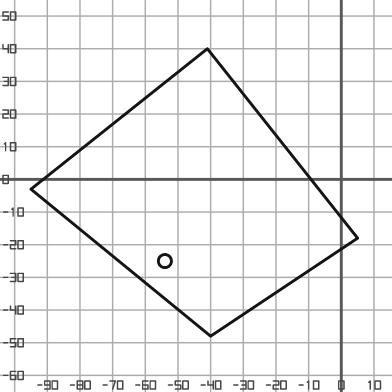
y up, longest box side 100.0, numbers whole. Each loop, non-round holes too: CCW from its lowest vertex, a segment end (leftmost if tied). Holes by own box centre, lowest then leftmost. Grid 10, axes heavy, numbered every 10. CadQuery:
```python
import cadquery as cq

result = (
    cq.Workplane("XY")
    .moveTo(-40.0, -48.0)
    .lineTo(5.0, -18.0)
    .lineTo(-41.0, 40.0)
    .lineTo(-95.0, -3.0)
    .close()
    .moveTo(-54.0, -25.0)
    .circle(2.0)
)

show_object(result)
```